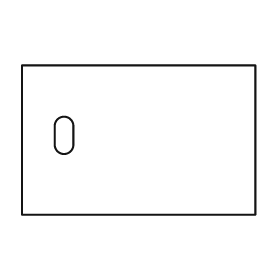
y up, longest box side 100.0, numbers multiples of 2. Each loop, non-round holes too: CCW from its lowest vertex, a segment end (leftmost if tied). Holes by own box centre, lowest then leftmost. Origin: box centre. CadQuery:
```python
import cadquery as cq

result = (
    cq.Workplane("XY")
    .moveTo(-50.0, -32.0)
    .lineTo(50.0, -32.0)
    .lineTo(50.0, 32.0)
    .lineTo(-50.0, 32.0)
    .close()
    .moveTo(-36.0, -2.0)
    .threePointArc((-32.0, -6.0), (-28.0, -2.0))
    .lineTo(-28.0, 6.0)
    .threePointArc((-32.0, 10.0), (-36.0, 6.0))
    .close()
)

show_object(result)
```